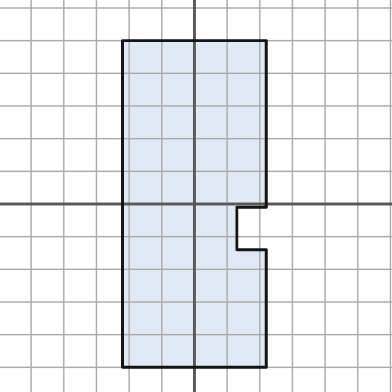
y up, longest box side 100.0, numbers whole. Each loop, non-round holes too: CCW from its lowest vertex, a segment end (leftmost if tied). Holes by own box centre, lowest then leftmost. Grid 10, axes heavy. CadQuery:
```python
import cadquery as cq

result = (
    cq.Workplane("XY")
    .moveTo(-22.0, -50.0)
    .lineTo(22.0, -50.0)
    .lineTo(22.0, -14.0)
    .lineTo(13.0, -14.0)
    .lineTo(13.0, -1.0)
    .lineTo(22.0, -1.0)
    .lineTo(22.0, 50.0)
    .lineTo(-22.0, 50.0)
    .close()
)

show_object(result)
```